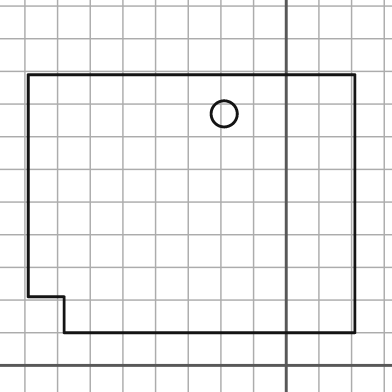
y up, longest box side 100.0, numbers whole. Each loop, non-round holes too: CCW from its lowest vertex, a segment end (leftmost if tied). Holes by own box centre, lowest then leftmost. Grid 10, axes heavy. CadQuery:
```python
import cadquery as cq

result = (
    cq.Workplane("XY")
    .moveTo(-68.0, 10.0)
    .lineTo(21.0, 10.0)
    .lineTo(21.0, 89.0)
    .lineTo(-79.0, 89.0)
    .lineTo(-79.0, 21.0)
    .lineTo(-68.0, 21.0)
    .close()
    .moveTo(-19.0, 77.0)
    .circle(4.0)
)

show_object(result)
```